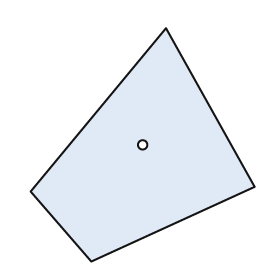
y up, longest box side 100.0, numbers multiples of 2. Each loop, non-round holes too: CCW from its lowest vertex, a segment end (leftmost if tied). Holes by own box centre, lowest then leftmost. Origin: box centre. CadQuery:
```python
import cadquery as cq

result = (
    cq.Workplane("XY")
    .moveTo(-22.0, -50.0)
    .lineTo(48.0, -18.0)
    .lineTo(10.0, 50.0)
    .lineTo(-48.0, -20.0)
    .close()
    .moveTo(0.0, 0.0)
    .circle(2.0)
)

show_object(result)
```